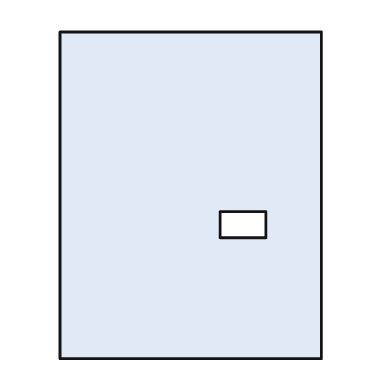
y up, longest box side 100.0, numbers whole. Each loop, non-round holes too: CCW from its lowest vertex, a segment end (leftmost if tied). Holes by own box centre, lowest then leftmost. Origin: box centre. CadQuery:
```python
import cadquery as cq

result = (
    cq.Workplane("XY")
    .moveTo(-40.0, -50.0)
    .lineTo(40.0, -50.0)
    .lineTo(40.0, 50.0)
    .lineTo(-40.0, 50.0)
    .close()
    .moveTo(9.0, -13.0)
    .lineTo(23.0, -13.0)
    .lineTo(23.0, -5.0)
    .lineTo(9.0, -5.0)
    .close()
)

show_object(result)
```